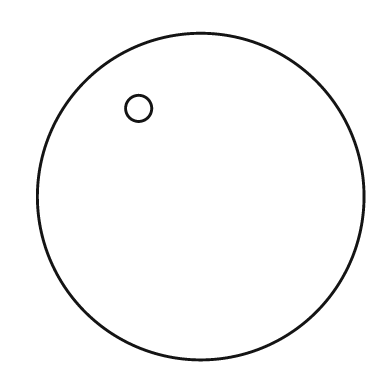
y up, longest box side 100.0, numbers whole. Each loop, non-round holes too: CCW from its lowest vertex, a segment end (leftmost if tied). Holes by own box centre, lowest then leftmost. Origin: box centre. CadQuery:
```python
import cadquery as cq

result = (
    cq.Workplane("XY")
    .moveTo(0.0, 0.0)
    .circle(50.0)
    .moveTo(-19.0, 27.0)
    .circle(4.0)
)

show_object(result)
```